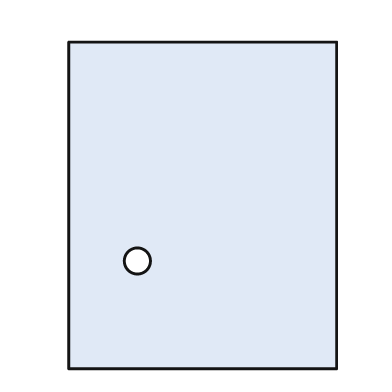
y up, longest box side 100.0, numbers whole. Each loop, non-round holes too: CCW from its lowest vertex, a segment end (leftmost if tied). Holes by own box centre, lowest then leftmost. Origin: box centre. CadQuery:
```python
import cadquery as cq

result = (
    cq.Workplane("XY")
    .moveTo(-41.0, -50.0)
    .lineTo(41.0, -50.0)
    .lineTo(41.0, 50.0)
    .lineTo(-41.0, 50.0)
    .close()
    .moveTo(-20.0, -17.0)
    .circle(4.0)
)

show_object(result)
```